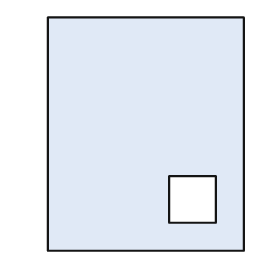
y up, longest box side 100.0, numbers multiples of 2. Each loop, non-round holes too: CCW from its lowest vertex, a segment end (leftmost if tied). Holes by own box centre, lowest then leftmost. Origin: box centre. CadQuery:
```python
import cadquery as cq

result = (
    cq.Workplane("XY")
    .moveTo(-42.0, -50.0)
    .lineTo(42.0, -50.0)
    .lineTo(42.0, 50.0)
    .lineTo(-42.0, 50.0)
    .close()
    .moveTo(10.0, -38.0)
    .lineTo(30.0, -38.0)
    .lineTo(30.0, -18.0)
    .lineTo(10.0, -18.0)
    .close()
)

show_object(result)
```